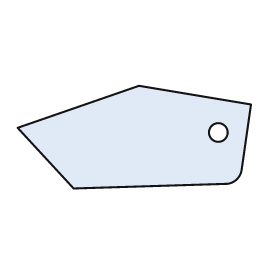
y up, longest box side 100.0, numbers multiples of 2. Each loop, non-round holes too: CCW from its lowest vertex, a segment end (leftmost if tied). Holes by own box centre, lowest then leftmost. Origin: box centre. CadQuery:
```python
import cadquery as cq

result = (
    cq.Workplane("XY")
    .moveTo(-26.0, -22.0)
    .lineTo(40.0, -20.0)
    .threePointArc((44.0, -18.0), (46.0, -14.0))
    .lineTo(50.0, 14.0)
    .lineTo(2.0, 22.0)
    .lineTo(-50.0, 4.0)
    .close()
    .moveTo(36.0, 2.0)
    .circle(4.0)
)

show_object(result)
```